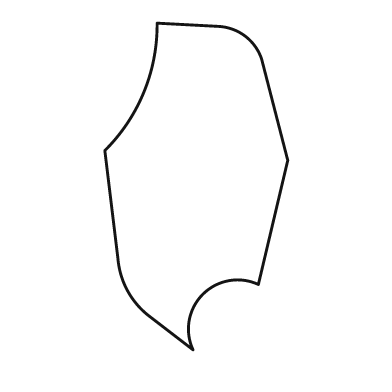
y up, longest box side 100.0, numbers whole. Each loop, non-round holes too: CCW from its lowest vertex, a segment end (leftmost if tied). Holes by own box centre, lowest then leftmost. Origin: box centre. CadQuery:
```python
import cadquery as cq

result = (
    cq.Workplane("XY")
    .moveTo(-1.0, -50.0)
    .threePointArc((2.0, -33.0), (19.0, -30.0))
    .lineTo(28.0, 8.0)
    .lineTo(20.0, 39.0)
    .threePointArc((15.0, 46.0), (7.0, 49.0))
    .lineTo(-12.0, 50.0)
    .threePointArc((-16.0, 29.0), (-28.0, 11.0))
    .lineTo(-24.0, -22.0)
    .threePointArc((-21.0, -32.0), (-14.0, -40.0))
    .close()
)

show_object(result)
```